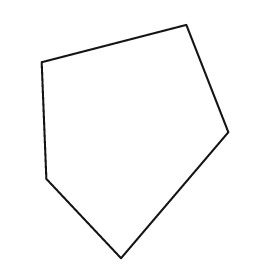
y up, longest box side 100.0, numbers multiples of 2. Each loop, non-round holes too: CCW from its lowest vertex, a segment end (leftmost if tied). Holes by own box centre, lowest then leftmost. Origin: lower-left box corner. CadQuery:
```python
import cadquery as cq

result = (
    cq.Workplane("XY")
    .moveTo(34.0, 0.0)
    .lineTo(80.0, 54.0)
    .lineTo(62.0, 100.0)
    .lineTo(0.0, 84.0)
    .lineTo(2.0, 34.0)
    .close()
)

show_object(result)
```